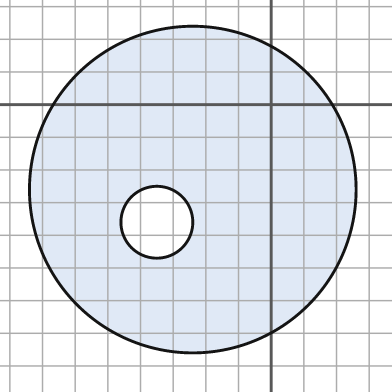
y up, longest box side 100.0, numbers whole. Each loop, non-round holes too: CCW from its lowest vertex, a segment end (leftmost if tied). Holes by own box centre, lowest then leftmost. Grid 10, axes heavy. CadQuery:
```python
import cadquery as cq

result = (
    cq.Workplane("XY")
    .moveTo(-24.0, -26.0)
    .circle(50.0)
    .moveTo(-35.0, -36.0)
    .circle(11.0)
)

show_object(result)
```